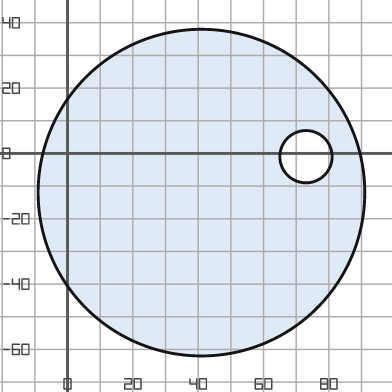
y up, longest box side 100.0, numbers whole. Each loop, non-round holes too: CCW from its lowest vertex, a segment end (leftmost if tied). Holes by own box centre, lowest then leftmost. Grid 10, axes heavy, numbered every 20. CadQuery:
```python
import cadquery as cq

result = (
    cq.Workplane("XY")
    .moveTo(41.0, -12.0)
    .circle(50.0)
    .moveTo(73.0, -1.0)
    .circle(8.0)
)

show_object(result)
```